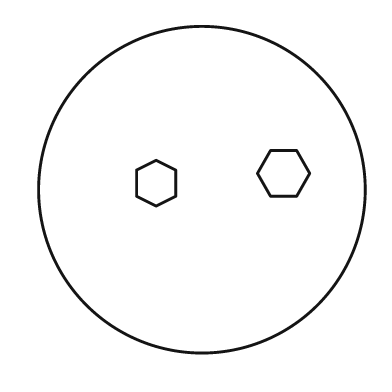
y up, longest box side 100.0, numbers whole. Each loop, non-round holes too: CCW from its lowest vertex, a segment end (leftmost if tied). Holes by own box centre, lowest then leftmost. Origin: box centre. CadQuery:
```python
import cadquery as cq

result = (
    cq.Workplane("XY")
    .moveTo(0.0, 0.0)
    .circle(50.0)
    .moveTo(-14.0, -5.0)
    .lineTo(-8.0, -2.0)
    .lineTo(-8.0, 6.0)
    .lineTo(-14.0, 9.0)
    .lineTo(-20.0, 6.0)
    .lineTo(-20.0, -2.0)
    .close()
    .moveTo(21.0, -2.0)
    .lineTo(29.0, -2.0)
    .lineTo(33.0, 5.0)
    .lineTo(29.0, 12.0)
    .lineTo(21.0, 12.0)
    .lineTo(17.0, 5.0)
    .close()
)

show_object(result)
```